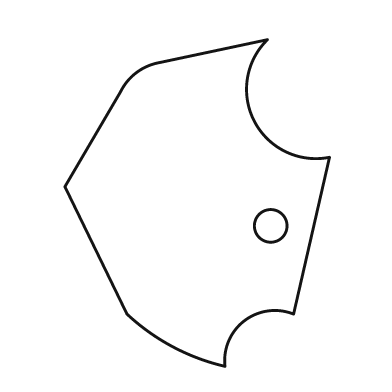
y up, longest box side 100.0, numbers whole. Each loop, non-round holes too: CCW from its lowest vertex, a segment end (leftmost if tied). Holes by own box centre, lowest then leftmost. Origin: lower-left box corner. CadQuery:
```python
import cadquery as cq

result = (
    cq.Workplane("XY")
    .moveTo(49.0, 0.0)
    .threePointArc((55.0, 14.0), (70.0, 16.0))
    .lineTo(81.0, 64.0)
    .threePointArc((58.0, 75.0), (62.0, 100.0))
    .lineTo(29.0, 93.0)
    .threePointArc((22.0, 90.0), (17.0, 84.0))
    .lineTo(0.0, 55.0)
    .lineTo(19.0, 16.0)
    .threePointArc((33.0, 6.0), (49.0, 0.0))
    .close()
    .moveTo(63.0, 43.0)
    .circle(5.0)
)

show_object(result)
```